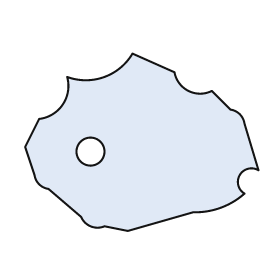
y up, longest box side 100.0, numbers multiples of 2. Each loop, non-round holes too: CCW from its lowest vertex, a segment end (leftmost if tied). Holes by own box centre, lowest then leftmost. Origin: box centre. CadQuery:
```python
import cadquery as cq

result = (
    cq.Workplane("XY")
    .moveTo(-6.0, -38.0)
    .lineTo(22.0, -30.0)
    .threePointArc((34.0, -28.0), (44.0, -22.0))
    .threePointArc((42.0, -14.0), (50.0, -12.0))
    .lineTo(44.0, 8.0)
    .threePointArc((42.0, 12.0), (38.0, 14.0))
    .lineTo(30.0, 22.0)
    .threePointArc((20.0, 22.0), (14.0, 30.0))
    .lineTo(-4.0, 38.0)
    .threePointArc((-16.0, 28.0), (-32.0, 28.0))
    .threePointArc((-34.0, 16.0), (-44.0, 10.0))
    .lineTo(-50.0, -2.0)
    .lineTo(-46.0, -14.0)
    .threePointArc((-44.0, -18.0), (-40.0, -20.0))
    .lineTo(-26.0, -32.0)
    .threePointArc((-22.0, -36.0), (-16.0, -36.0))
    .close()
    .moveTo(-22.0, -4.0)
    .circle(6.0)
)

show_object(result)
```